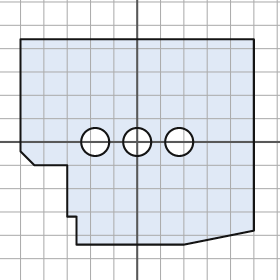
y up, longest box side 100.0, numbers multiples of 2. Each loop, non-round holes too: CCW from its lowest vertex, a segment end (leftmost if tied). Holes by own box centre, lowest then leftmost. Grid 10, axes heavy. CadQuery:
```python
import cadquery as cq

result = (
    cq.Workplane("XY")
    .moveTo(-26.0, -44.0)
    .lineTo(20.0, -44.0)
    .lineTo(50.0, -38.0)
    .lineTo(50.0, 44.0)
    .lineTo(-50.0, 44.0)
    .lineTo(-50.0, -4.0)
    .lineTo(-44.0, -10.0)
    .lineTo(-30.0, -10.0)
    .lineTo(-30.0, -32.0)
    .lineTo(-26.0, -32.0)
    .close()
    .moveTo(-18.0, 0.0)
    .circle(6.0)
    .moveTo(0.0, 0.0)
    .circle(6.0)
    .moveTo(18.0, 0.0)
    .circle(6.0)
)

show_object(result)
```